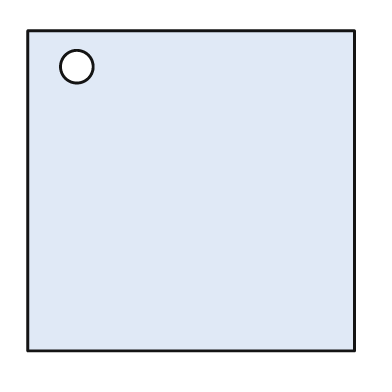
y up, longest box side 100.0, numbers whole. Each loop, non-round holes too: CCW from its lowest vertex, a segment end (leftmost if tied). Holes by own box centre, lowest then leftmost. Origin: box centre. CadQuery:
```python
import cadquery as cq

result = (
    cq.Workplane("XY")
    .moveTo(-50.0, -49.0)
    .lineTo(50.0, -49.0)
    .lineTo(50.0, 49.0)
    .lineTo(-50.0, 49.0)
    .close()
    .moveTo(-35.0, 38.0)
    .circle(5.0)
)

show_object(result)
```